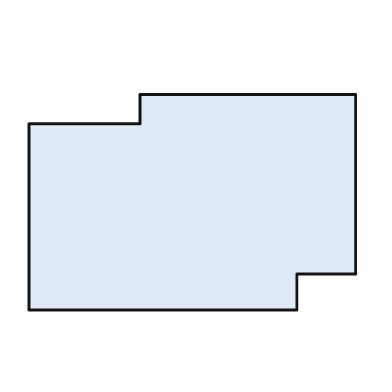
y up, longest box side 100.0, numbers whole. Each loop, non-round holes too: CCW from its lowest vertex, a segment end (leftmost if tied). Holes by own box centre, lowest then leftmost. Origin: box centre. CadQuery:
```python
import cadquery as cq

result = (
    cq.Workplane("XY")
    .moveTo(-50.0, -33.0)
    .lineTo(32.0, -33.0)
    .lineTo(32.0, -22.0)
    .lineTo(50.0, -22.0)
    .lineTo(50.0, 33.0)
    .lineTo(-16.0, 33.0)
    .lineTo(-16.0, 24.0)
    .lineTo(-50.0, 24.0)
    .close()
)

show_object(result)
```